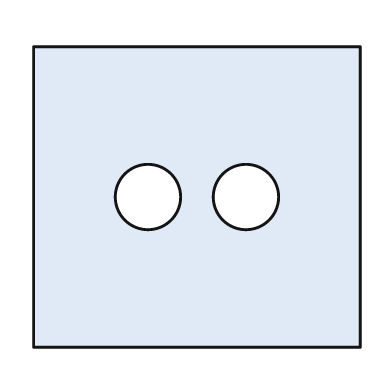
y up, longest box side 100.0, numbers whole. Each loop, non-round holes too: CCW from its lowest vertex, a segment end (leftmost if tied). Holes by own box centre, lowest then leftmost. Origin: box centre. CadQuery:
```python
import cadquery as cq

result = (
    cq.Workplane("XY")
    .moveTo(-50.0, -46.0)
    .lineTo(50.0, -46.0)
    .lineTo(50.0, 46.0)
    .lineTo(-50.0, 46.0)
    .close()
    .moveTo(-15.0, 0.0)
    .circle(10.0)
    .moveTo(15.0, 0.0)
    .circle(10.0)
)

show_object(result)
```